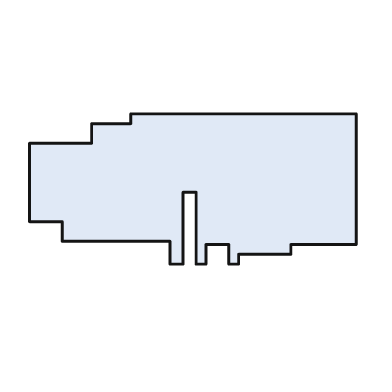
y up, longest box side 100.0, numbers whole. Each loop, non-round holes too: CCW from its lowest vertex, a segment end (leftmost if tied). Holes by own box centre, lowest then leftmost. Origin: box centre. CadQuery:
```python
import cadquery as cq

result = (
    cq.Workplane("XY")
    .moveTo(-7.0, -23.0)
    .lineTo(-3.0, -23.0)
    .lineTo(-3.0, -1.0)
    .lineTo(1.0, -1.0)
    .lineTo(1.0, -23.0)
    .lineTo(4.0, -23.0)
    .lineTo(4.0, -17.0)
    .lineTo(11.0, -17.0)
    .lineTo(11.0, -23.0)
    .lineTo(14.0, -23.0)
    .lineTo(14.0, -20.0)
    .lineTo(30.0, -20.0)
    .lineTo(30.0, -17.0)
    .lineTo(50.0, -17.0)
    .lineTo(50.0, 23.0)
    .lineTo(-19.0, 23.0)
    .lineTo(-19.0, 20.0)
    .lineTo(-31.0, 20.0)
    .lineTo(-31.0, 14.0)
    .lineTo(-50.0, 14.0)
    .lineTo(-50.0, -10.0)
    .lineTo(-40.0, -10.0)
    .lineTo(-40.0, -16.0)
    .lineTo(-7.0, -16.0)
    .close()
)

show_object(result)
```